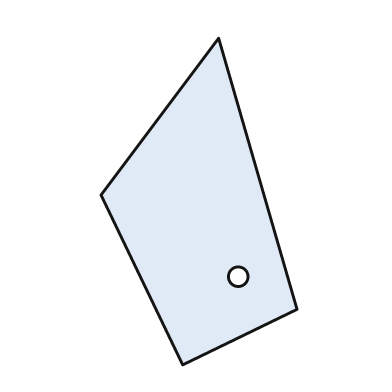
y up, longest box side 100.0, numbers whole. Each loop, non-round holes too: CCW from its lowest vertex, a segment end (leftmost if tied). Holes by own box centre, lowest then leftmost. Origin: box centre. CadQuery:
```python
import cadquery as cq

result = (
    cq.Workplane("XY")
    .moveTo(-5.0, -50.0)
    .lineTo(30.0, -33.0)
    .lineTo(6.0, 50.0)
    .lineTo(-30.0, 2.0)
    .close()
    .moveTo(12.0, -23.0)
    .circle(3.0)
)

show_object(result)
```